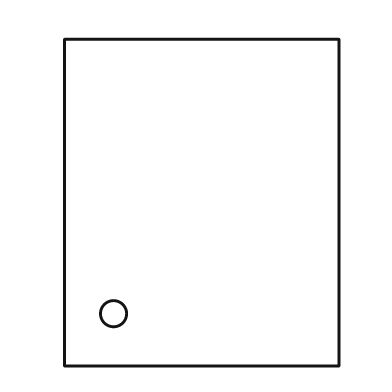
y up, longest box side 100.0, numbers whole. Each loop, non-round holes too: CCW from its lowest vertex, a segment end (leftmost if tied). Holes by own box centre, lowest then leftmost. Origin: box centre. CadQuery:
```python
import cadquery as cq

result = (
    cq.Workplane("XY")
    .moveTo(-42.0, -50.0)
    .lineTo(42.0, -50.0)
    .lineTo(42.0, 50.0)
    .lineTo(-42.0, 50.0)
    .close()
    .moveTo(-27.0, -34.0)
    .circle(4.0)
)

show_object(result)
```